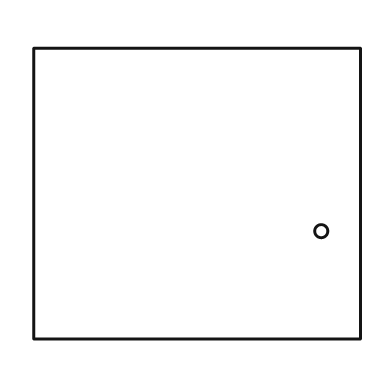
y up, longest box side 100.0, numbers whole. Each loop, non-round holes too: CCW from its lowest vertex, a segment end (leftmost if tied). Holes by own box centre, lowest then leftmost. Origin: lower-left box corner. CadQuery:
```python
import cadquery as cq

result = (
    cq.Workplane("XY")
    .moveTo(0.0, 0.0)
    .lineTo(100.0, 0.0)
    .lineTo(100.0, 89.0)
    .lineTo(0.0, 89.0)
    .close()
    .moveTo(88.0, 33.0)
    .circle(2.0)
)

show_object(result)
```